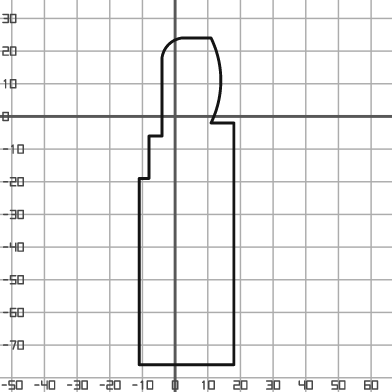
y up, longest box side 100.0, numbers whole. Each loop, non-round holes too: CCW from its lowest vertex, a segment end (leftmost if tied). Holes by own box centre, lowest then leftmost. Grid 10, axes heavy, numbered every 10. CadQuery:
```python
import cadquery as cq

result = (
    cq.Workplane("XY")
    .moveTo(-11.0, -76.0)
    .lineTo(18.0, -76.0)
    .lineTo(18.0, -2.0)
    .lineTo(11.0, -2.0)
    .threePointArc((14.0, 11.0), (11.0, 24.0))
    .lineTo(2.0, 24.0)
    .threePointArc((-2.0, 22.0), (-4.0, 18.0))
    .lineTo(-4.0, -6.0)
    .lineTo(-8.0, -6.0)
    .lineTo(-8.0, -19.0)
    .lineTo(-11.0, -19.0)
    .close()
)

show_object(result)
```